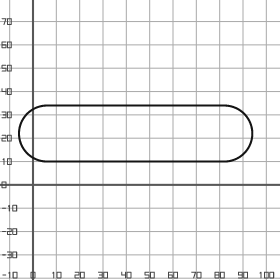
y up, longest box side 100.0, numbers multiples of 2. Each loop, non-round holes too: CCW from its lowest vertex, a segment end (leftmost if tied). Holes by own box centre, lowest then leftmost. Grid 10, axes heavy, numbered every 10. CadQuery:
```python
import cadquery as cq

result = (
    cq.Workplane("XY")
    .moveTo(6.0, 10.0)
    .lineTo(82.0, 10.0)
    .threePointArc((94.0, 22.0), (82.0, 34.0))
    .lineTo(6.0, 34.0)
    .threePointArc((-6.0, 22.0), (6.0, 10.0))
    .close()
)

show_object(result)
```